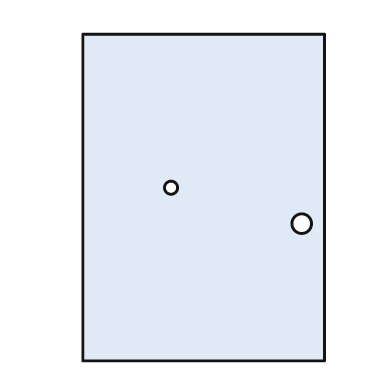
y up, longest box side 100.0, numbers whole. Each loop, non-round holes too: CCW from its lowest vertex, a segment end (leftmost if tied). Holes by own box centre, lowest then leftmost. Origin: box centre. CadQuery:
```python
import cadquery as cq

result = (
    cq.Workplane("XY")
    .moveTo(-37.0, -50.0)
    .lineTo(37.0, -50.0)
    .lineTo(37.0, 50.0)
    .lineTo(-37.0, 50.0)
    .close()
    .moveTo(30.0, -8.0)
    .circle(3.0)
    .moveTo(-10.0, 3.0)
    .circle(2.0)
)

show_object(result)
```